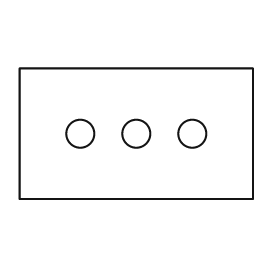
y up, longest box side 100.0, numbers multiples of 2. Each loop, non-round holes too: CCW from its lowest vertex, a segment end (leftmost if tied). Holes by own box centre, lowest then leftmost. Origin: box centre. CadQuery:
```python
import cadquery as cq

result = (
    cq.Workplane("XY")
    .moveTo(-50.0, -28.0)
    .lineTo(50.0, -28.0)
    .lineTo(50.0, 28.0)
    .lineTo(-50.0, 28.0)
    .close()
    .moveTo(-24.0, 0.0)
    .circle(6.0)
    .moveTo(0.0, 0.0)
    .circle(6.0)
    .moveTo(24.0, 0.0)
    .circle(6.0)
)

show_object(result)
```